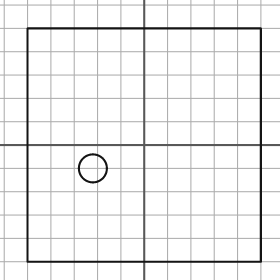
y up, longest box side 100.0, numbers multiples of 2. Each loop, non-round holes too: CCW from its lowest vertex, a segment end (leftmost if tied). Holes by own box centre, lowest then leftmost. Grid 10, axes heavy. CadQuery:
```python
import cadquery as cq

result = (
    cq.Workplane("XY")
    .moveTo(-50.0, -50.0)
    .lineTo(50.0, -50.0)
    .lineTo(50.0, 50.0)
    .lineTo(-50.0, 50.0)
    .close()
    .moveTo(-22.0, -10.0)
    .circle(6.0)
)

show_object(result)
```